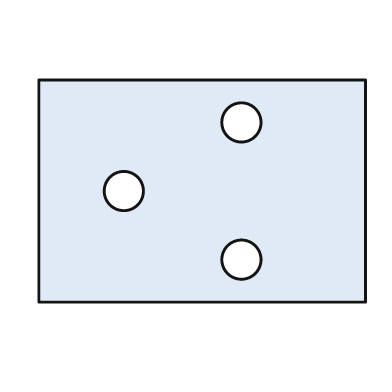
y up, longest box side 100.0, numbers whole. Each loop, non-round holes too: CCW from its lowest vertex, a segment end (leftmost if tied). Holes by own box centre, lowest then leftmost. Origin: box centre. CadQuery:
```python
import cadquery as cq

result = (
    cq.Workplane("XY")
    .moveTo(-50.0, -34.0)
    .lineTo(50.0, -34.0)
    .lineTo(50.0, 34.0)
    .lineTo(-50.0, 34.0)
    .close()
    .moveTo(12.0, -21.0)
    .circle(6.0)
    .moveTo(-24.0, 0.0)
    .circle(6.0)
    .moveTo(12.0, 21.0)
    .circle(6.0)
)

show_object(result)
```